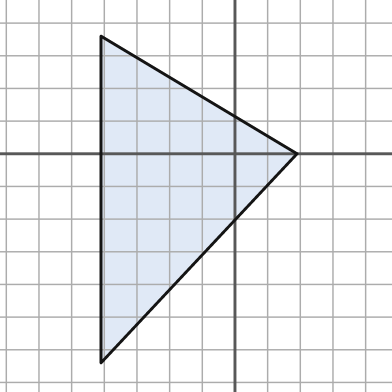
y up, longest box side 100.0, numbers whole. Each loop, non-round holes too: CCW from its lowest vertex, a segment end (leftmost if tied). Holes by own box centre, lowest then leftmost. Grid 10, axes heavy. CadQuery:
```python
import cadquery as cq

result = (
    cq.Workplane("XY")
    .moveTo(-41.0, -64.0)
    .lineTo(19.0, 0.0)
    .lineTo(-41.0, 36.0)
    .close()
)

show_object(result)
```